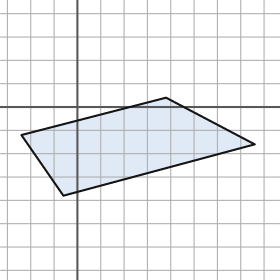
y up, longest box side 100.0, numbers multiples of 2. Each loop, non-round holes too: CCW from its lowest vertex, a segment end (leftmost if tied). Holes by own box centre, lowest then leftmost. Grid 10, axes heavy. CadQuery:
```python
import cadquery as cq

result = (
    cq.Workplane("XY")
    .moveTo(-6.0, -38.0)
    .lineTo(76.0, -16.0)
    .lineTo(38.0, 4.0)
    .lineTo(-24.0, -12.0)
    .close()
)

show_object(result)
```